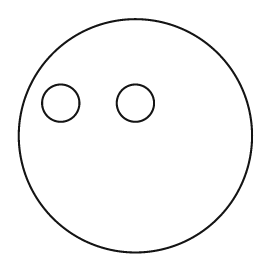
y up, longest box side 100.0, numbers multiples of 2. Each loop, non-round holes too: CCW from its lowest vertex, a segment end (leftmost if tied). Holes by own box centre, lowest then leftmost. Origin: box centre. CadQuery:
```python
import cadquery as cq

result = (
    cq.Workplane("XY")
    .moveTo(0.0, 0.0)
    .circle(50.0)
    .moveTo(-32.0, 14.0)
    .circle(8.0)
    .moveTo(0.0, 14.0)
    .circle(8.0)
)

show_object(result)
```